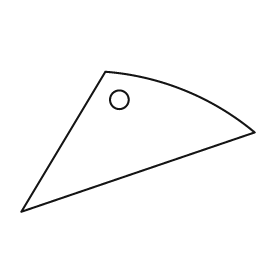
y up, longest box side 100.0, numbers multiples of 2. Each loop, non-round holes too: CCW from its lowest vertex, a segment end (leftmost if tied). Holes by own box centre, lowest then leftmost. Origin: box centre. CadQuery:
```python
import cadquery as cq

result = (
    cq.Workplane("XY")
    .moveTo(-50.0, -30.0)
    .lineTo(50.0, 4.0)
    .threePointArc((20.0, 22.0), (-14.0, 30.0))
    .close()
    .moveTo(-8.0, 18.0)
    .circle(4.0)
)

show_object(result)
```